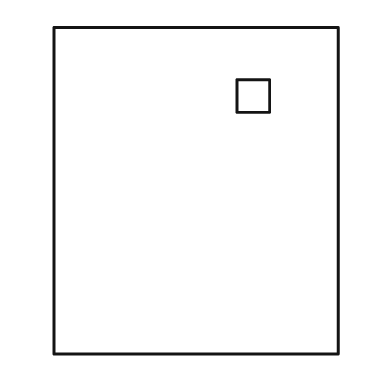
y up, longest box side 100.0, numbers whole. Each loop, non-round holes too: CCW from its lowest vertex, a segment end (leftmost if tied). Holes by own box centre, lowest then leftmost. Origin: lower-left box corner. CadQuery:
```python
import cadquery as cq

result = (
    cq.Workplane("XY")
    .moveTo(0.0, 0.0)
    .lineTo(87.0, 0.0)
    .lineTo(87.0, 100.0)
    .lineTo(0.0, 100.0)
    .close()
    .moveTo(56.0, 74.0)
    .lineTo(66.0, 74.0)
    .lineTo(66.0, 84.0)
    .lineTo(56.0, 84.0)
    .close()
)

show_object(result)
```